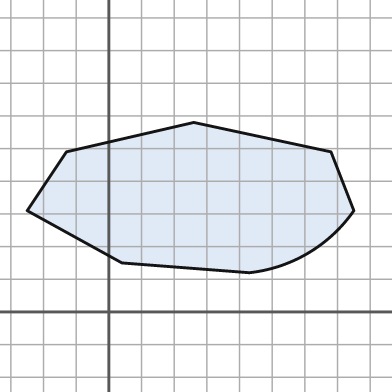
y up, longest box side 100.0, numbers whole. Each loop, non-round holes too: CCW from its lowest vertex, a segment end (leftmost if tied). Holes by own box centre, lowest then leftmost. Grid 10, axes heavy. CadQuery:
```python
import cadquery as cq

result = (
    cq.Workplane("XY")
    .moveTo(43.0, 12.0)
    .threePointArc((61.0, 18.0), (75.0, 31.0))
    .lineTo(68.0, 49.0)
    .lineTo(26.0, 58.0)
    .lineTo(-13.0, 49.0)
    .lineTo(-25.0, 31.0)
    .lineTo(4.0, 15.0)
    .close()
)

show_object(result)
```